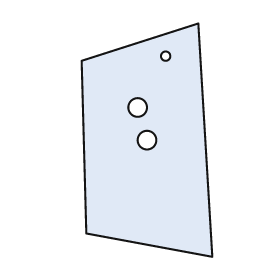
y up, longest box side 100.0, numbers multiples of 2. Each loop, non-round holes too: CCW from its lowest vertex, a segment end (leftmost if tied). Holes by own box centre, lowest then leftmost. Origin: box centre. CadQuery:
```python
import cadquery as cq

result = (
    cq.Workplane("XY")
    .moveTo(28.0, -50.0)
    .lineTo(22.0, 50.0)
    .lineTo(-28.0, 34.0)
    .lineTo(-26.0, -40.0)
    .close()
    .moveTo(0.0, 0.0)
    .circle(4.0)
    .moveTo(-4.0, 14.0)
    .circle(4.0)
    .moveTo(8.0, 36.0)
    .circle(2.0)
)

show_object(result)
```